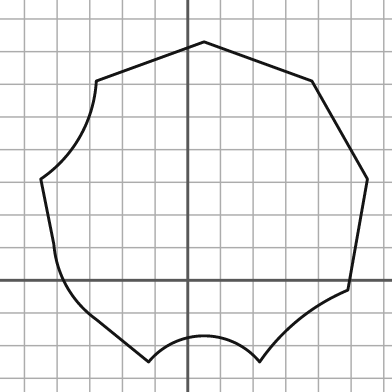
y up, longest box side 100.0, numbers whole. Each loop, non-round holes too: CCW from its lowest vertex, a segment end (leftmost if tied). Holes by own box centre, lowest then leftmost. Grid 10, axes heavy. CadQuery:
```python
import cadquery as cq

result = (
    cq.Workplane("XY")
    .moveTo(-12.0, -25.0)
    .threePointArc((5.0, -17.0), (22.0, -25.0))
    .threePointArc((34.0, -12.0), (49.0, -3.0))
    .lineTo(55.0, 31.0)
    .lineTo(38.0, 61.0)
    .lineTo(5.0, 73.0)
    .lineTo(-28.0, 61.0)
    .threePointArc((-33.0, 44.0), (-45.0, 31.0))
    .lineTo(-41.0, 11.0)
    .threePointArc((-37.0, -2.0), (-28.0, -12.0))
    .close()
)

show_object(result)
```